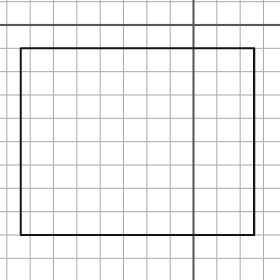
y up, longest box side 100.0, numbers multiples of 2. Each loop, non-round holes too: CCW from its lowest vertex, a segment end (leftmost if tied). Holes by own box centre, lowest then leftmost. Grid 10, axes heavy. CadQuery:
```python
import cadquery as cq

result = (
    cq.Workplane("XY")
    .moveTo(-74.0, -90.0)
    .lineTo(26.0, -90.0)
    .lineTo(26.0, -10.0)
    .lineTo(-74.0, -10.0)
    .close()
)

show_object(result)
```